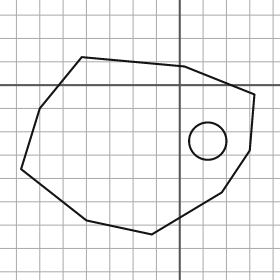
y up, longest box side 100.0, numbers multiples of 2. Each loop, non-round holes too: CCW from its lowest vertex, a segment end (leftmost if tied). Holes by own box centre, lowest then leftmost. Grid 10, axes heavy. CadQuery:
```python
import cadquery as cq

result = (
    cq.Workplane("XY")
    .moveTo(-12.0, -64.0)
    .lineTo(18.0, -46.0)
    .lineTo(30.0, -28.0)
    .lineTo(32.0, -4.0)
    .lineTo(2.0, 8.0)
    .lineTo(-42.0, 12.0)
    .lineTo(-60.0, -10.0)
    .lineTo(-68.0, -36.0)
    .lineTo(-40.0, -58.0)
    .close()
    .moveTo(12.0, -24.0)
    .circle(8.0)
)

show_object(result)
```